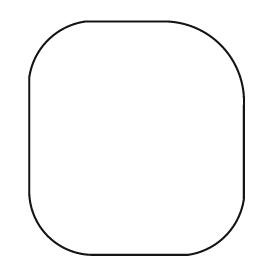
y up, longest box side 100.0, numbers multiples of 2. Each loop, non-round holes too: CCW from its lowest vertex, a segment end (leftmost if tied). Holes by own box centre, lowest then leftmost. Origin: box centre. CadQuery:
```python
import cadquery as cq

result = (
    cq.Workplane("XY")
    .moveTo(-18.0, -50.0)
    .lineTo(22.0, -50.0)
    .threePointArc((38.0, -42.0), (46.0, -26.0))
    .lineTo(46.0, 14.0)
    .threePointArc((36.0, 40.0), (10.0, 50.0))
    .lineTo(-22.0, 50.0)
    .threePointArc((-38.0, 42.0), (-46.0, 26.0))
    .lineTo(-46.0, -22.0)
    .threePointArc((-38.0, -42.0), (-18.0, -50.0))
    .close()
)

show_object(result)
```